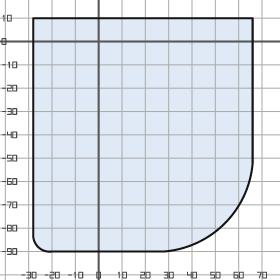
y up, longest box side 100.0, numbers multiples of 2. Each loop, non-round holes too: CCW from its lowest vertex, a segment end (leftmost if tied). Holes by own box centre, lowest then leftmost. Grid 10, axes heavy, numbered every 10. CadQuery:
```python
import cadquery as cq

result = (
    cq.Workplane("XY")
    .moveTo(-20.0, -90.0)
    .lineTo(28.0, -90.0)
    .threePointArc((54.0, -78.0), (66.0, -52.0))
    .lineTo(66.0, 10.0)
    .lineTo(-28.0, 10.0)
    .lineTo(-28.0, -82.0)
    .threePointArc((-26.0, -88.0), (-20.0, -90.0))
    .close()
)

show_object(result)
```